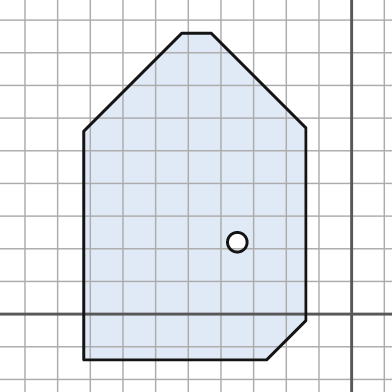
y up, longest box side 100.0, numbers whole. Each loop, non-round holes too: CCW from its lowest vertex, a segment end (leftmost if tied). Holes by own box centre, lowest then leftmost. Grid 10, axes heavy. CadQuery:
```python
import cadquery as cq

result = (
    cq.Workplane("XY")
    .moveTo(-82.0, -14.0)
    .lineTo(-26.0, -14.0)
    .lineTo(-14.0, -2.0)
    .lineTo(-14.0, 57.0)
    .lineTo(-43.0, 86.0)
    .lineTo(-52.0, 86.0)
    .lineTo(-82.0, 56.0)
    .close()
    .moveTo(-35.0, 22.0)
    .circle(3.0)
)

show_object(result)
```